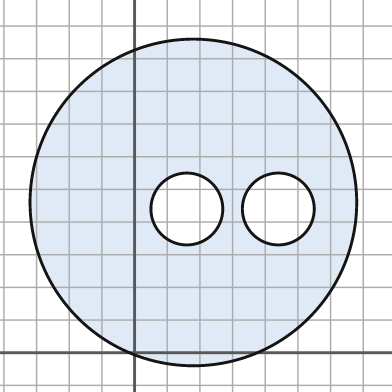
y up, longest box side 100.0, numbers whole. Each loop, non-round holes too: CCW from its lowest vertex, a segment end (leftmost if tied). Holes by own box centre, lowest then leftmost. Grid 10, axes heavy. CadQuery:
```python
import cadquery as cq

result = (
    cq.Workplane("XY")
    .moveTo(18.0, 46.0)
    .circle(50.0)
    .moveTo(16.0, 44.0)
    .circle(11.0)
    .moveTo(44.0, 44.0)
    .circle(11.0)
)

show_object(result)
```